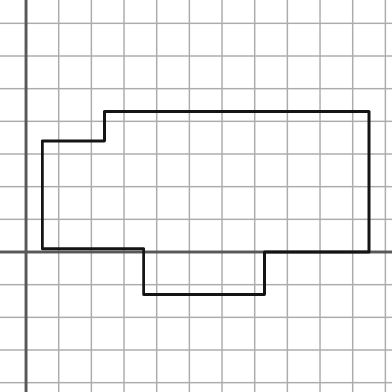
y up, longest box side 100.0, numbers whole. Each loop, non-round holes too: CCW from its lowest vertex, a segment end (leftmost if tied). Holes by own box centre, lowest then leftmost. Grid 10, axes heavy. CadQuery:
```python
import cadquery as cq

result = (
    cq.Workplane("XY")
    .moveTo(36.0, -13.0)
    .lineTo(73.0, -13.0)
    .lineTo(73.0, 0.0)
    .lineTo(105.0, 0.0)
    .lineTo(105.0, 43.0)
    .lineTo(24.0, 43.0)
    .lineTo(24.0, 34.0)
    .lineTo(5.0, 34.0)
    .lineTo(5.0, 1.0)
    .lineTo(36.0, 1.0)
    .close()
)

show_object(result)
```